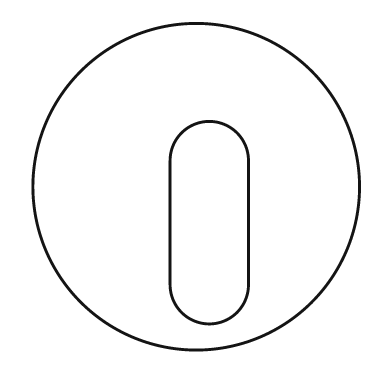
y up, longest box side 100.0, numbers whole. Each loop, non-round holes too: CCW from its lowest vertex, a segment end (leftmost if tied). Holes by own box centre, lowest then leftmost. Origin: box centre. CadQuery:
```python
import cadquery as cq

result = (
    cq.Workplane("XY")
    .moveTo(0.0, 0.0)
    .circle(50.0)
    .moveTo(-8.0, -30.0)
    .threePointArc((4.0, -42.0), (16.0, -30.0))
    .lineTo(16.0, 8.0)
    .threePointArc((4.0, 20.0), (-8.0, 8.0))
    .close()
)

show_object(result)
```